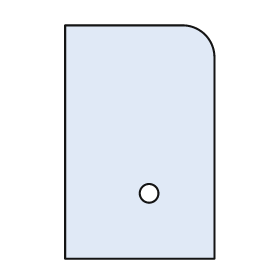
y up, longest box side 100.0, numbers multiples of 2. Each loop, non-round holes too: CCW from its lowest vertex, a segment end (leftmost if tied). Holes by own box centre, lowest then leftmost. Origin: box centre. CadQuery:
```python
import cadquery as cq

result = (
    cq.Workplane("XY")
    .moveTo(-32.0, -50.0)
    .lineTo(32.0, -50.0)
    .lineTo(32.0, 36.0)
    .threePointArc((28.0, 46.0), (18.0, 50.0))
    .lineTo(-32.0, 50.0)
    .close()
    .moveTo(4.0, -22.0)
    .circle(4.0)
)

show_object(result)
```